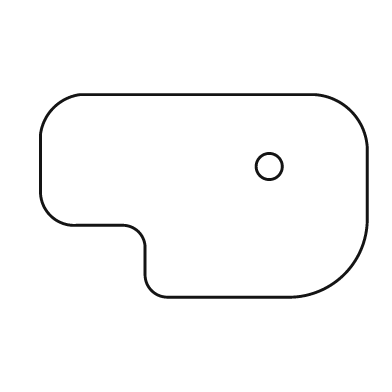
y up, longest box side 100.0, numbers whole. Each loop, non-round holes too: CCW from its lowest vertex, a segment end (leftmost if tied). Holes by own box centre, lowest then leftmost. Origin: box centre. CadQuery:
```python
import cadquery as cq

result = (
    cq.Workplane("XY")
    .moveTo(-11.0, -31.0)
    .lineTo(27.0, -31.0)
    .threePointArc((43.0, -24.0), (50.0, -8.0))
    .lineTo(50.0, 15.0)
    .threePointArc((45.0, 26.0), (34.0, 31.0))
    .lineTo(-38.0, 31.0)
    .threePointArc((-46.0, 27.0), (-50.0, 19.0))
    .lineTo(-50.0, 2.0)
    .threePointArc((-47.0, -6.0), (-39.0, -9.0))
    .lineTo(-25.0, -9.0)
    .threePointArc((-20.0, -11.0), (-18.0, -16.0))
    .lineTo(-18.0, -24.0)
    .threePointArc((-16.0, -29.0), (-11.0, -31.0))
    .close()
    .moveTo(20.0, 9.0)
    .circle(4.0)
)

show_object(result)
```